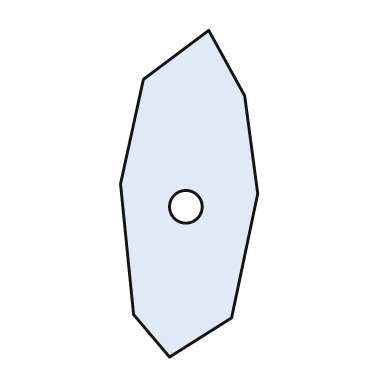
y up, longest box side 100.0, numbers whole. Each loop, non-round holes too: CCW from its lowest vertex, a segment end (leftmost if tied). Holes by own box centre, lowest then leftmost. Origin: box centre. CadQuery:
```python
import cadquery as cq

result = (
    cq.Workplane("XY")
    .moveTo(-6.0, -50.0)
    .lineTo(13.0, -38.0)
    .lineTo(21.0, 0.0)
    .lineTo(17.0, 30.0)
    .lineTo(6.0, 50.0)
    .lineTo(-14.0, 35.0)
    .lineTo(-21.0, 3.0)
    .lineTo(-17.0, -37.0)
    .close()
    .moveTo(-1.0, -4.0)
    .circle(5.0)
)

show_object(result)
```